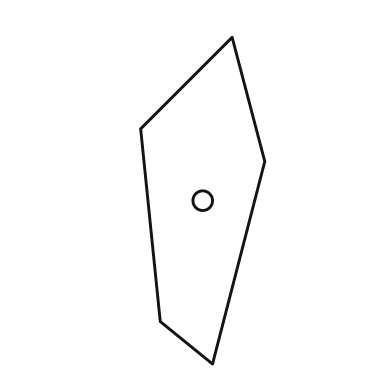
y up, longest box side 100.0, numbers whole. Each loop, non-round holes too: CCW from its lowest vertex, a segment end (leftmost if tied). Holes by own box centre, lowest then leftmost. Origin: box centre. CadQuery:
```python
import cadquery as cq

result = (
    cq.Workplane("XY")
    .moveTo(3.0, -50.0)
    .lineTo(19.0, 12.0)
    .lineTo(9.0, 50.0)
    .lineTo(-19.0, 22.0)
    .lineTo(-13.0, -37.0)
    .close()
    .moveTo(0.0, 0.0)
    .circle(3.0)
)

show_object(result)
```